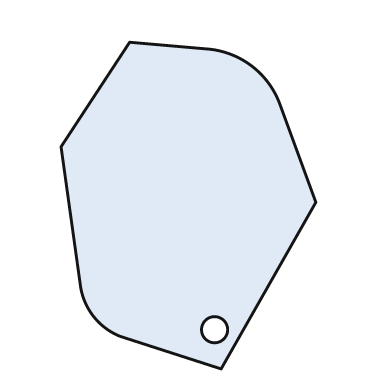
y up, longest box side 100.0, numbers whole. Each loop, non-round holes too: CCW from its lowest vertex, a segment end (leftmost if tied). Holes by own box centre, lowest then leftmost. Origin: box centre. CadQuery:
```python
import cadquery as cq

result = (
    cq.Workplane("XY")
    .moveTo(10.0, -50.0)
    .lineTo(39.0, 1.0)
    .lineTo(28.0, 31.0)
    .threePointArc((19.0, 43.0), (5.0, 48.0))
    .lineTo(-18.0, 50.0)
    .lineTo(-39.0, 18.0)
    .lineTo(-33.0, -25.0)
    .threePointArc((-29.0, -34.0), (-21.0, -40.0))
    .close()
    .moveTo(8.0, -38.0)
    .circle(4.0)
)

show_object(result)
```